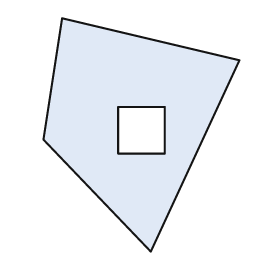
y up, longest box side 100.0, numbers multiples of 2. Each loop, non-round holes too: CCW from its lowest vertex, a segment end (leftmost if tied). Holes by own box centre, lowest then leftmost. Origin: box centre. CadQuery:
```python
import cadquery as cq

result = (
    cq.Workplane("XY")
    .moveTo(4.0, -50.0)
    .lineTo(42.0, 32.0)
    .lineTo(-34.0, 50.0)
    .lineTo(-42.0, -2.0)
    .close()
    .moveTo(-10.0, -8.0)
    .lineTo(10.0, -8.0)
    .lineTo(10.0, 12.0)
    .lineTo(-10.0, 12.0)
    .close()
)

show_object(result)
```